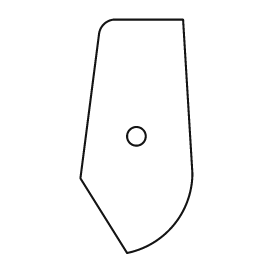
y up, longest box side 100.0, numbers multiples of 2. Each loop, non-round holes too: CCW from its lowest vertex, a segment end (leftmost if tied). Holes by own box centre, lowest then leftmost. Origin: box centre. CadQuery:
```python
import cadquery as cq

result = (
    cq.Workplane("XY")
    .moveTo(-4.0, -50.0)
    .threePointArc((16.0, -38.0), (24.0, -16.0))
    .lineTo(20.0, 50.0)
    .lineTo(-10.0, 50.0)
    .threePointArc((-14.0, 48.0), (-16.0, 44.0))
    .lineTo(-24.0, -18.0)
    .close()
    .moveTo(0.0, 0.0)
    .circle(4.0)
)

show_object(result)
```